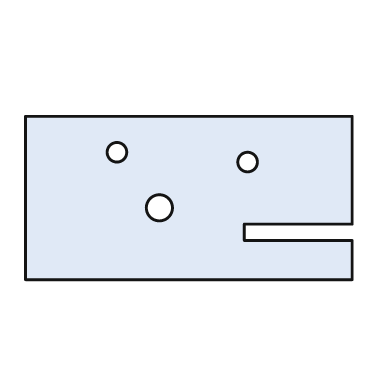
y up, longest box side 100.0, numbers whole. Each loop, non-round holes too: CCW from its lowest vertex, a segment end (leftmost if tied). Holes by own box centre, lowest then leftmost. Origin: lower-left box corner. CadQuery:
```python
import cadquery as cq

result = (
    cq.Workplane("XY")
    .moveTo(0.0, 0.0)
    .lineTo(100.0, 0.0)
    .lineTo(100.0, 12.0)
    .lineTo(67.0, 12.0)
    .lineTo(67.0, 17.0)
    .lineTo(100.0, 17.0)
    .lineTo(100.0, 50.0)
    .lineTo(0.0, 50.0)
    .close()
    .moveTo(41.0, 22.0)
    .circle(4.0)
    .moveTo(68.0, 36.0)
    .circle(3.0)
    .moveTo(28.0, 39.0)
    .circle(3.0)
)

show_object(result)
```